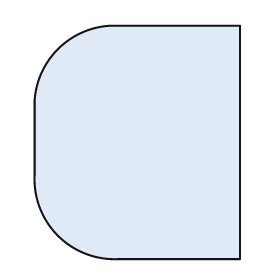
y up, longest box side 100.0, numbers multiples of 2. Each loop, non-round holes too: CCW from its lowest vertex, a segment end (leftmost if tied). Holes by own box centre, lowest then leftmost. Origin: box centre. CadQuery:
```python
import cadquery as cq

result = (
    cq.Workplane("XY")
    .moveTo(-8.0, -50.0)
    .lineTo(44.0, -50.0)
    .lineTo(44.0, 50.0)
    .lineTo(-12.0, 50.0)
    .threePointArc((-34.0, 40.0), (-44.0, 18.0))
    .lineTo(-44.0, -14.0)
    .threePointArc((-34.0, -40.0), (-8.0, -50.0))
    .close()
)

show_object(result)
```